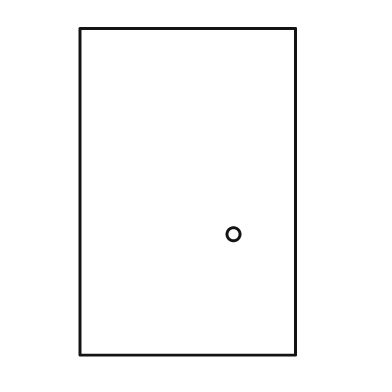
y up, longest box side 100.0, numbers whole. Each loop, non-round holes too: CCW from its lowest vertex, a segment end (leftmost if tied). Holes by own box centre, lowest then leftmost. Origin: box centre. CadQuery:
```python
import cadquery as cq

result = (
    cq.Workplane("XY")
    .moveTo(-33.0, -50.0)
    .lineTo(33.0, -50.0)
    .lineTo(33.0, 50.0)
    .lineTo(-33.0, 50.0)
    .close()
    .moveTo(14.0, -13.0)
    .circle(2.0)
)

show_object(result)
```